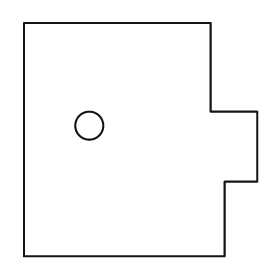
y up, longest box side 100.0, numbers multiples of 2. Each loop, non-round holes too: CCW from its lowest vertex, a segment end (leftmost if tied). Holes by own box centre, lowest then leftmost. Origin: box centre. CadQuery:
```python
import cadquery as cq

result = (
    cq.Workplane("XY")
    .moveTo(-50.0, -50.0)
    .lineTo(36.0, -50.0)
    .lineTo(36.0, -18.0)
    .lineTo(50.0, -18.0)
    .lineTo(50.0, 12.0)
    .lineTo(30.0, 12.0)
    .lineTo(30.0, 50.0)
    .lineTo(-50.0, 50.0)
    .close()
    .moveTo(-22.0, 6.0)
    .circle(6.0)
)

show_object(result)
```